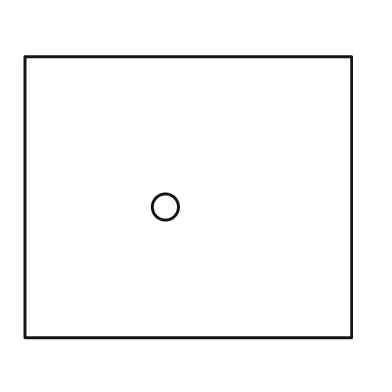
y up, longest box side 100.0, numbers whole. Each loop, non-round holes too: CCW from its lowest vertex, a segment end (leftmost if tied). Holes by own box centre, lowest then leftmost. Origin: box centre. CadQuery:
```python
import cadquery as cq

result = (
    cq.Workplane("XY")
    .moveTo(-50.0, -43.0)
    .lineTo(50.0, -43.0)
    .lineTo(50.0, 43.0)
    .lineTo(-50.0, 43.0)
    .close()
    .moveTo(-7.0, -3.0)
    .circle(4.0)
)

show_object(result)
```